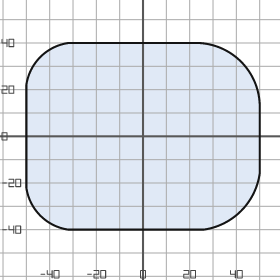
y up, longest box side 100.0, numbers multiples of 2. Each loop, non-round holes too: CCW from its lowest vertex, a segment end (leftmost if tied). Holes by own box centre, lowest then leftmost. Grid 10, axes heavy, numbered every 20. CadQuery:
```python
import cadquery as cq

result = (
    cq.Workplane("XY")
    .moveTo(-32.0, -40.0)
    .lineTo(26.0, -40.0)
    .threePointArc((42.0, -32.0), (50.0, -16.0))
    .lineTo(50.0, 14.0)
    .threePointArc((42.0, 32.0), (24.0, 40.0))
    .lineTo(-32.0, 40.0)
    .threePointArc((-44.0, 34.0), (-50.0, 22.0))
    .lineTo(-50.0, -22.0)
    .threePointArc((-44.0, -34.0), (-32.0, -40.0))
    .close()
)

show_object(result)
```